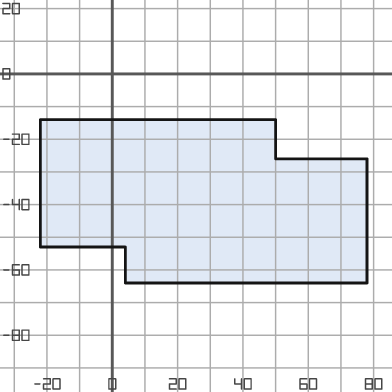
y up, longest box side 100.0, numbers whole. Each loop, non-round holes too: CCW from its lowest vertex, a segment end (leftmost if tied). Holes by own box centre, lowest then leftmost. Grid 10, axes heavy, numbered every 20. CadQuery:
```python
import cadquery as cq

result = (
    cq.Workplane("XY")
    .moveTo(4.0, -64.0)
    .lineTo(78.0, -64.0)
    .lineTo(78.0, -26.0)
    .lineTo(50.0, -26.0)
    .lineTo(50.0, -14.0)
    .lineTo(-22.0, -14.0)
    .lineTo(-22.0, -53.0)
    .lineTo(4.0, -53.0)
    .close()
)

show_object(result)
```